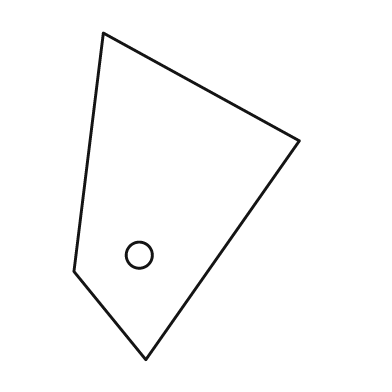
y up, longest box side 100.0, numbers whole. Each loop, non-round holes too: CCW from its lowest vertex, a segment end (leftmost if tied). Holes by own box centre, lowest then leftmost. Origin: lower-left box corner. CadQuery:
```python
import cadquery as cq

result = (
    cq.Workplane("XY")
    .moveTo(22.0, 0.0)
    .lineTo(69.0, 67.0)
    .lineTo(9.0, 100.0)
    .lineTo(0.0, 27.0)
    .close()
    .moveTo(20.0, 32.0)
    .circle(4.0)
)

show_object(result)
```